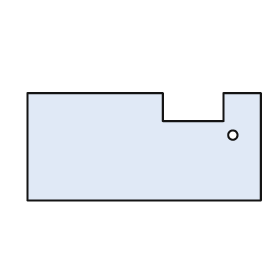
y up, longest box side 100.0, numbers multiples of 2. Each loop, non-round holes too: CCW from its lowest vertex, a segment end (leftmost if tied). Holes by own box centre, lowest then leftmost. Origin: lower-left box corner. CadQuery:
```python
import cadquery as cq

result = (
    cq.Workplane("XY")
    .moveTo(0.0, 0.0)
    .lineTo(100.0, 0.0)
    .lineTo(100.0, 46.0)
    .lineTo(84.0, 46.0)
    .lineTo(84.0, 34.0)
    .lineTo(58.0, 34.0)
    .lineTo(58.0, 46.0)
    .lineTo(0.0, 46.0)
    .close()
    .moveTo(88.0, 28.0)
    .circle(2.0)
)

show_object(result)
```